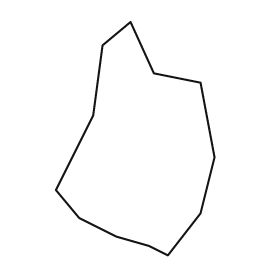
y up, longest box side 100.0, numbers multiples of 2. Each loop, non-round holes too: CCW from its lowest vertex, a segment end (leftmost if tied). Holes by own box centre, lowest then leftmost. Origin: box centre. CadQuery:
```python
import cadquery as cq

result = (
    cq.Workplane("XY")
    .moveTo(14.0, -50.0)
    .lineTo(28.0, -32.0)
    .lineTo(34.0, -8.0)
    .lineTo(28.0, 24.0)
    .lineTo(8.0, 28.0)
    .lineTo(-2.0, 50.0)
    .lineTo(-14.0, 40.0)
    .lineTo(-18.0, 10.0)
    .lineTo(-34.0, -22.0)
    .lineTo(-24.0, -34.0)
    .lineTo(-8.0, -42.0)
    .lineTo(6.0, -46.0)
    .close()
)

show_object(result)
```